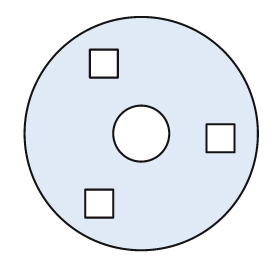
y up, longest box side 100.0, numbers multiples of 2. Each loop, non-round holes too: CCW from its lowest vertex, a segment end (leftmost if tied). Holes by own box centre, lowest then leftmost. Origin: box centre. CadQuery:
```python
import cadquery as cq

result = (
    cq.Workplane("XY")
    .moveTo(0.0, 0.0)
    .circle(50.0)
    .moveTo(-24.0, -36.0)
    .lineTo(-12.0, -36.0)
    .lineTo(-12.0, -24.0)
    .lineTo(-24.0, -24.0)
    .close()
    .moveTo(28.0, -8.0)
    .lineTo(40.0, -8.0)
    .lineTo(40.0, 4.0)
    .lineTo(28.0, 4.0)
    .close()
    .moveTo(0.0, 0.0)
    .circle(12.0)
    .moveTo(-22.0, 24.0)
    .lineTo(-10.0, 24.0)
    .lineTo(-10.0, 36.0)
    .lineTo(-22.0, 36.0)
    .close()
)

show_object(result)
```